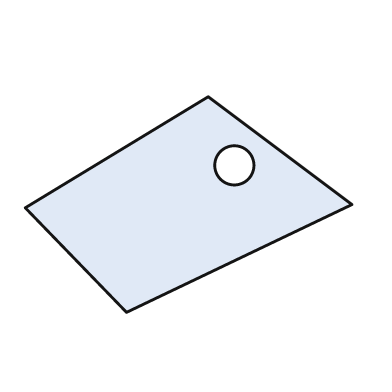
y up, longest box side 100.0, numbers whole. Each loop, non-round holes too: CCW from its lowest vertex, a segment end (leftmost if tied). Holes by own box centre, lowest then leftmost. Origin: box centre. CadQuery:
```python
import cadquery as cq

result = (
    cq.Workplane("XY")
    .moveTo(-19.0, -33.0)
    .lineTo(50.0, 0.0)
    .lineTo(6.0, 33.0)
    .lineTo(-50.0, -1.0)
    .close()
    .moveTo(14.0, 12.0)
    .circle(6.0)
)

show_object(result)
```